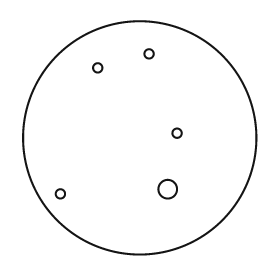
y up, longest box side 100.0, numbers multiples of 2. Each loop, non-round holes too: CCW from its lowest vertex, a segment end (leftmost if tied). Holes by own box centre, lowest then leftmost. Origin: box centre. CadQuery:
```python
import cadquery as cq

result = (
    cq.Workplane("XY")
    .moveTo(0.0, 0.0)
    .circle(50.0)
    .moveTo(-34.0, -24.0)
    .circle(2.0)
    .moveTo(12.0, -22.0)
    .circle(4.0)
    .moveTo(16.0, 2.0)
    .circle(2.0)
    .moveTo(-18.0, 30.0)
    .circle(2.0)
    .moveTo(4.0, 36.0)
    .circle(2.0)
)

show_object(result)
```